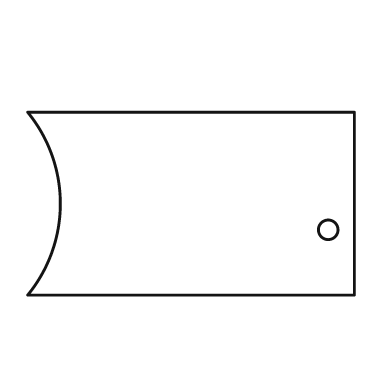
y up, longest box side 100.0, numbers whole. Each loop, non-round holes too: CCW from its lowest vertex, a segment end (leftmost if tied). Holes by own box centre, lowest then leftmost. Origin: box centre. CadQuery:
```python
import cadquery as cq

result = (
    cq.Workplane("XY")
    .moveTo(-50.0, -28.0)
    .lineTo(50.0, -28.0)
    .lineTo(50.0, 28.0)
    .lineTo(-50.0, 28.0)
    .threePointArc((-40.0, 0.0), (-50.0, -28.0))
    .close()
    .moveTo(42.0, -8.0)
    .circle(3.0)
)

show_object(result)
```